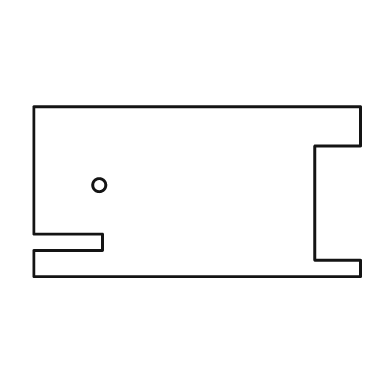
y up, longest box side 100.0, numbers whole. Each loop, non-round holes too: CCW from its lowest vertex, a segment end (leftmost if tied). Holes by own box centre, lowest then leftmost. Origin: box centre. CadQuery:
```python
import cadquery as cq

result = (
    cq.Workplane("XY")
    .moveTo(-50.0, -26.0)
    .lineTo(50.0, -26.0)
    .lineTo(50.0, -21.0)
    .lineTo(36.0, -21.0)
    .lineTo(36.0, 14.0)
    .lineTo(50.0, 14.0)
    .lineTo(50.0, 26.0)
    .lineTo(-50.0, 26.0)
    .lineTo(-50.0, -13.0)
    .lineTo(-29.0, -13.0)
    .lineTo(-29.0, -18.0)
    .lineTo(-50.0, -18.0)
    .close()
    .moveTo(-30.0, 2.0)
    .circle(2.0)
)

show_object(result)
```